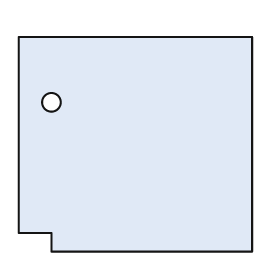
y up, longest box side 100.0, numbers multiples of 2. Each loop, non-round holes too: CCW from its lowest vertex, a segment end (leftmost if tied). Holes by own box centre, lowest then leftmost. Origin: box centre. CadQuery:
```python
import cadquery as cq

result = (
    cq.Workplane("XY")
    .moveTo(-36.0, -46.0)
    .lineTo(50.0, -46.0)
    .lineTo(50.0, 46.0)
    .lineTo(-50.0, 46.0)
    .lineTo(-50.0, -38.0)
    .lineTo(-36.0, -38.0)
    .close()
    .moveTo(-36.0, 18.0)
    .circle(4.0)
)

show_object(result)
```